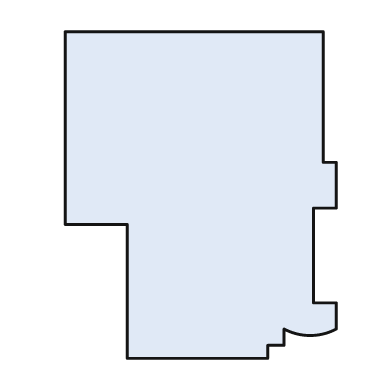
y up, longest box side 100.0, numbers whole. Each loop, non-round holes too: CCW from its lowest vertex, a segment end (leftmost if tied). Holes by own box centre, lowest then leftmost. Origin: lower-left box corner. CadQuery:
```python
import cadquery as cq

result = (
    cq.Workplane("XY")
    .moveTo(19.0, 0.0)
    .lineTo(62.0, 0.0)
    .lineTo(62.0, 4.0)
    .lineTo(67.0, 4.0)
    .lineTo(67.0, 9.0)
    .threePointArc((75.0, 7.0), (83.0, 9.0))
    .lineTo(83.0, 17.0)
    .lineTo(76.0, 17.0)
    .lineTo(76.0, 46.0)
    .lineTo(83.0, 46.0)
    .lineTo(83.0, 60.0)
    .lineTo(79.0, 60.0)
    .lineTo(79.0, 100.0)
    .lineTo(0.0, 100.0)
    .lineTo(0.0, 41.0)
    .lineTo(19.0, 41.0)
    .close()
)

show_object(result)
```